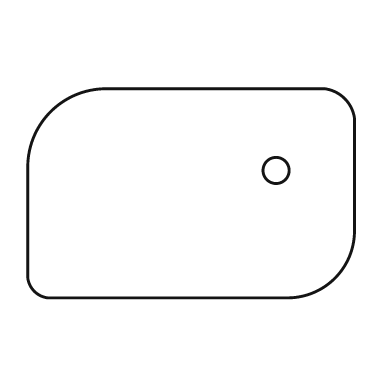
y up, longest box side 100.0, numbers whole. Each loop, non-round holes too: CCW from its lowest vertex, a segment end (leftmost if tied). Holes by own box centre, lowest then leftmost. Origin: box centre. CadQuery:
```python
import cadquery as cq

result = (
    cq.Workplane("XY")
    .moveTo(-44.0, -32.0)
    .lineTo(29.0, -32.0)
    .threePointArc((44.0, -26.0), (50.0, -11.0))
    .lineTo(50.0, 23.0)
    .threePointArc((47.0, 29.0), (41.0, 32.0))
    .lineTo(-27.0, 32.0)
    .threePointArc((-43.0, 25.0), (-50.0, 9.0))
    .lineTo(-50.0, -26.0)
    .threePointArc((-48.0, -30.0), (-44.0, -32.0))
    .close()
    .moveTo(26.0, 7.0)
    .circle(4.0)
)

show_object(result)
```